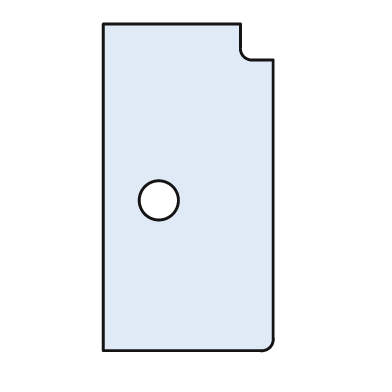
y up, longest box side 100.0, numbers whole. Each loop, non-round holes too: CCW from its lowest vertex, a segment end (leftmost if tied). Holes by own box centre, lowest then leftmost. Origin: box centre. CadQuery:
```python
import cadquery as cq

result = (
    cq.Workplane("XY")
    .moveTo(-26.0, -50.0)
    .lineTo(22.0, -50.0)
    .threePointArc((25.0, -49.0), (26.0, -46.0))
    .lineTo(26.0, 39.0)
    .lineTo(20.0, 39.0)
    .threePointArc((17.0, 40.0), (16.0, 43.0))
    .lineTo(16.0, 50.0)
    .lineTo(-26.0, 50.0)
    .close()
    .moveTo(-9.0, -4.0)
    .circle(6.0)
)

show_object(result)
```